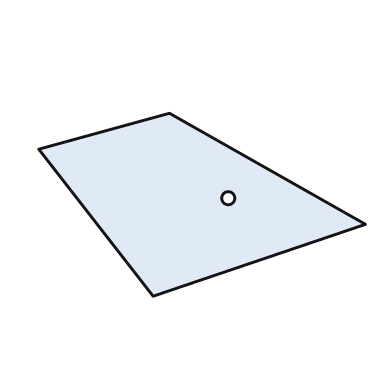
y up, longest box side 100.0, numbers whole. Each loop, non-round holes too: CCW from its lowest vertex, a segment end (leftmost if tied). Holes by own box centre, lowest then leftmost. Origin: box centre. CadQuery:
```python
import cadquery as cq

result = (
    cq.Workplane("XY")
    .moveTo(-15.0, -28.0)
    .lineTo(50.0, -6.0)
    .lineTo(-10.0, 28.0)
    .lineTo(-50.0, 17.0)
    .close()
    .moveTo(8.0, 2.0)
    .circle(2.0)
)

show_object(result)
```